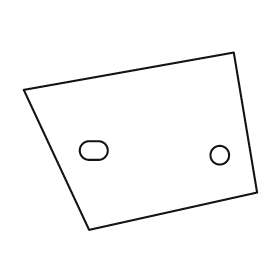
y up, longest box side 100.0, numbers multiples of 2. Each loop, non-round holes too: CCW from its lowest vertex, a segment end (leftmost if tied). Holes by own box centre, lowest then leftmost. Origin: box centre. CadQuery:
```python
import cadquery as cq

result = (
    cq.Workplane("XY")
    .moveTo(-22.0, -38.0)
    .lineTo(50.0, -22.0)
    .lineTo(40.0, 38.0)
    .lineTo(-50.0, 22.0)
    .close()
    .moveTo(34.0, -6.0)
    .circle(4.0)
    .moveTo(-22.0, -8.0)
    .lineTo(-18.0, -8.0)
    .threePointArc((-14.0, -4.0), (-18.0, 0.0))
    .lineTo(-22.0, 0.0)
    .threePointArc((-26.0, -4.0), (-22.0, -8.0))
    .close()
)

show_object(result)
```